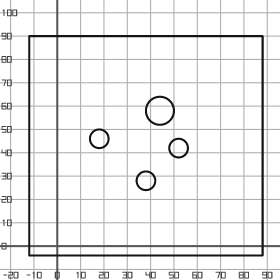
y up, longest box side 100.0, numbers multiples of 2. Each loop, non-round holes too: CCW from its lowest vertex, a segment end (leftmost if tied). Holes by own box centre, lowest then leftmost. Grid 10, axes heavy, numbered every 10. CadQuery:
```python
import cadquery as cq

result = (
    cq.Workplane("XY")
    .moveTo(-12.0, -4.0)
    .lineTo(88.0, -4.0)
    .lineTo(88.0, 90.0)
    .lineTo(-12.0, 90.0)
    .close()
    .moveTo(38.0, 28.0)
    .circle(4.0)
    .moveTo(52.0, 42.0)
    .circle(4.0)
    .moveTo(18.0, 46.0)
    .circle(4.0)
    .moveTo(44.0, 58.0)
    .circle(6.0)
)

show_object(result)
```